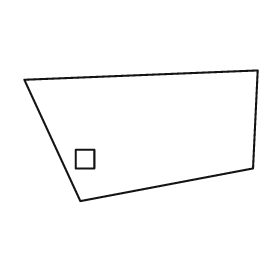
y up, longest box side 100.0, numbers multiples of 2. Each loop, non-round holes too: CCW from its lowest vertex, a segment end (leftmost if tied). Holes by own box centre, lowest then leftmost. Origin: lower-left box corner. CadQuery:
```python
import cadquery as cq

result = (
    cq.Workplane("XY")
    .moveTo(24.0, 0.0)
    .lineTo(98.0, 14.0)
    .lineTo(100.0, 56.0)
    .lineTo(0.0, 52.0)
    .close()
    .moveTo(22.0, 14.0)
    .lineTo(30.0, 14.0)
    .lineTo(30.0, 22.0)
    .lineTo(22.0, 22.0)
    .close()
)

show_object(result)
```